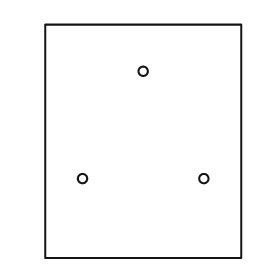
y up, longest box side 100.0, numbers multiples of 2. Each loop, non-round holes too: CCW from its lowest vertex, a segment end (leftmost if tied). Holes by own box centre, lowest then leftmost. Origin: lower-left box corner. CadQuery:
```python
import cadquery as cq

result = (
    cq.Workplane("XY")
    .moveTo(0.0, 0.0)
    .lineTo(84.0, 0.0)
    .lineTo(84.0, 100.0)
    .lineTo(0.0, 100.0)
    .close()
    .moveTo(16.0, 34.0)
    .circle(2.0)
    .moveTo(68.0, 34.0)
    .circle(2.0)
    .moveTo(42.0, 80.0)
    .circle(2.0)
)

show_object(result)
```